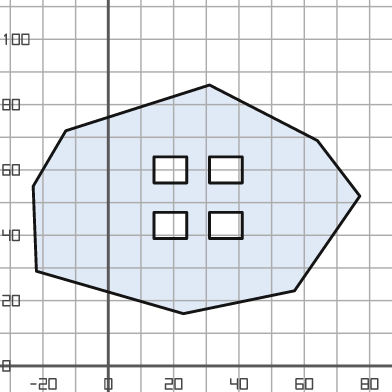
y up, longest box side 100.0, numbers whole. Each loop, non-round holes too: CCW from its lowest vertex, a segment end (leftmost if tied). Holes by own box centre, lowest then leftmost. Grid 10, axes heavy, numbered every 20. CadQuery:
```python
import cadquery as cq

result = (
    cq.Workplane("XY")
    .moveTo(23.0, 16.0)
    .lineTo(57.0, 23.0)
    .lineTo(77.0, 52.0)
    .lineTo(64.0, 69.0)
    .lineTo(31.0, 86.0)
    .lineTo(-13.0, 72.0)
    .lineTo(-23.0, 55.0)
    .lineTo(-22.0, 29.0)
    .close()
    .moveTo(14.0, 39.0)
    .lineTo(24.0, 39.0)
    .lineTo(24.0, 47.0)
    .lineTo(14.0, 47.0)
    .close()
    .moveTo(31.0, 39.0)
    .lineTo(41.0, 39.0)
    .lineTo(41.0, 47.0)
    .lineTo(31.0, 47.0)
    .close()
    .moveTo(14.0, 56.0)
    .lineTo(24.0, 56.0)
    .lineTo(24.0, 64.0)
    .lineTo(14.0, 64.0)
    .close()
    .moveTo(31.0, 56.0)
    .lineTo(41.0, 56.0)
    .lineTo(41.0, 64.0)
    .lineTo(31.0, 64.0)
    .close()
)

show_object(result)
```